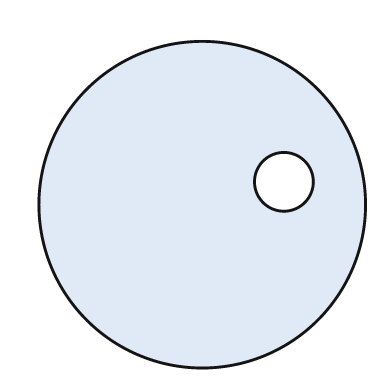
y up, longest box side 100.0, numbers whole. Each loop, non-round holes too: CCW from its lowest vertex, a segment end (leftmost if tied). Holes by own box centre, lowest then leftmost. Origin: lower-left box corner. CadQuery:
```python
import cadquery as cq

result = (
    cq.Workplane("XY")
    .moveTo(50.0, 50.0)
    .circle(50.0)
    .moveTo(75.0, 57.0)
    .circle(9.0)
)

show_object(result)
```